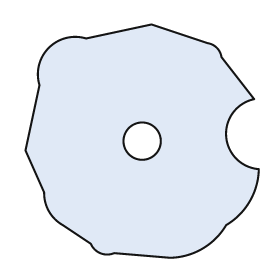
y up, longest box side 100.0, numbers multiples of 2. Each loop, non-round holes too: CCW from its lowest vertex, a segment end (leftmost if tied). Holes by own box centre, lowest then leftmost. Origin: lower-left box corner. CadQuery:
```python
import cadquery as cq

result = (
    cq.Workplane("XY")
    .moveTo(62.0, 0.0)
    .threePointArc((76.0, 4.0), (86.0, 14.0))
    .threePointArc((96.0, 24.0), (100.0, 38.0))
    .threePointArc((86.0, 52.0), (98.0, 68.0))
    .lineTo(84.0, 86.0)
    .threePointArc((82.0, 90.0), (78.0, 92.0))
    .lineTo(54.0, 100.0)
    .lineTo(26.0, 94.0)
    .threePointArc((10.0, 90.0), (6.0, 74.0))
    .lineTo(0.0, 46.0)
    .lineTo(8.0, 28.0)
    .threePointArc((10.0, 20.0), (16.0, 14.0))
    .lineTo(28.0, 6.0)
    .threePointArc((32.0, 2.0), (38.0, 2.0))
    .close()
    .moveTo(50.0, 50.0)
    .circle(8.0)
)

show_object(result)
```